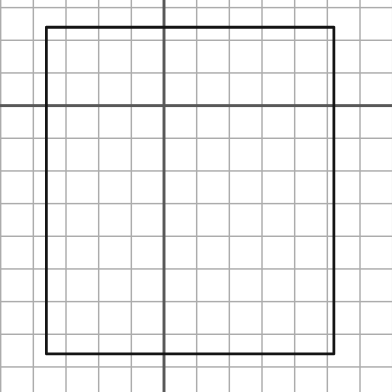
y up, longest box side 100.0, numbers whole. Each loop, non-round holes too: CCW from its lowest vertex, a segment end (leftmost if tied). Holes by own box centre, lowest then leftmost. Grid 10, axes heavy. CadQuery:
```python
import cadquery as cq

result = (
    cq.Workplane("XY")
    .moveTo(-36.0, -76.0)
    .lineTo(52.0, -76.0)
    .lineTo(52.0, 24.0)
    .lineTo(-36.0, 24.0)
    .close()
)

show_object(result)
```